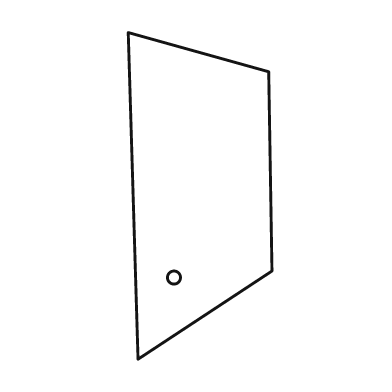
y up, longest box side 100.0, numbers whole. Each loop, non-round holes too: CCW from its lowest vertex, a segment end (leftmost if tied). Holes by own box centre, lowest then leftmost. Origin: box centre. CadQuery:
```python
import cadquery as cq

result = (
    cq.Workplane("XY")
    .moveTo(-19.0, -50.0)
    .lineTo(22.0, -23.0)
    .lineTo(21.0, 38.0)
    .lineTo(-22.0, 50.0)
    .close()
    .moveTo(-8.0, -25.0)
    .circle(2.0)
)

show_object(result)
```